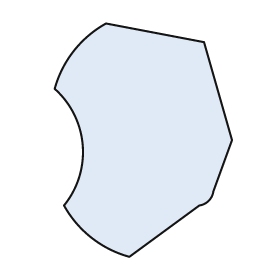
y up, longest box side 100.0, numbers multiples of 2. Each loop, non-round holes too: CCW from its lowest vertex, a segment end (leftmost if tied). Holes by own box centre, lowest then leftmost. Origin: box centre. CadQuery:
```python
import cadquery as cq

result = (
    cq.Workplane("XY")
    .moveTo(-6.0, -50.0)
    .lineTo(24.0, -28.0)
    .threePointArc((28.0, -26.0), (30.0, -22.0))
    .lineTo(38.0, 0.0)
    .lineTo(26.0, 42.0)
    .lineTo(-16.0, 50.0)
    .threePointArc((-30.0, 38.0), (-38.0, 22.0))
    .threePointArc((-26.0, -2.0), (-34.0, -28.0))
    .threePointArc((-22.0, -42.0), (-6.0, -50.0))
    .close()
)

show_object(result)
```